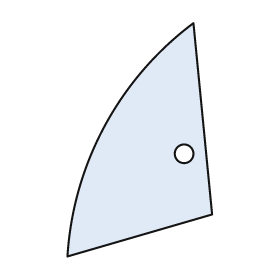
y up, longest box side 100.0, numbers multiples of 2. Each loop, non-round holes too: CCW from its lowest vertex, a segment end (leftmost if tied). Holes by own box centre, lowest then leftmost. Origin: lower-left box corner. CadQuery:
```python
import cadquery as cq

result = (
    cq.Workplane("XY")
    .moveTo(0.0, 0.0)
    .lineTo(62.0, 18.0)
    .lineTo(54.0, 100.0)
    .threePointArc((16.0, 56.0), (0.0, 0.0))
    .close()
    .moveTo(50.0, 44.0)
    .circle(4.0)
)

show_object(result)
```